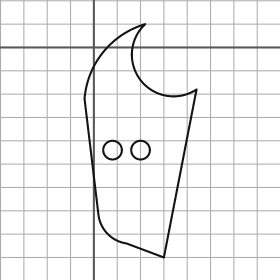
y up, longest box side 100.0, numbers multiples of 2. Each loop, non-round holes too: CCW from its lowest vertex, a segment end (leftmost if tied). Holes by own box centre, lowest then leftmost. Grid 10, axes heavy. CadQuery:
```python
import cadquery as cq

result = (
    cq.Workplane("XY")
    .moveTo(30.0, -90.0)
    .lineTo(44.0, -18.0)
    .threePointArc((20.0, -14.0), (22.0, 10.0))
    .threePointArc((4.0, -2.0), (-4.0, -22.0))
    .lineTo(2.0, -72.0)
    .threePointArc((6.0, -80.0), (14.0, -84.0))
    .close()
    .moveTo(8.0, -44.0)
    .circle(4.0)
    .moveTo(20.0, -44.0)
    .circle(4.0)
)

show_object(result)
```